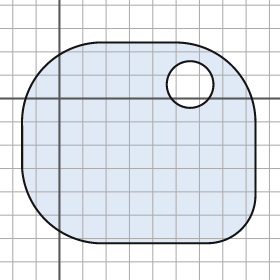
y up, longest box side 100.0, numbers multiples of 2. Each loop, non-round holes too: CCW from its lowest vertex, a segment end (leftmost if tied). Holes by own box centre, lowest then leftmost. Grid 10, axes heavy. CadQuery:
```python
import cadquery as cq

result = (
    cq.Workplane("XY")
    .moveTo(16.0, -62.0)
    .lineTo(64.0, -62.0)
    .threePointArc((78.0, -56.0), (84.0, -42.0))
    .lineTo(84.0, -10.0)
    .threePointArc((74.0, 14.0), (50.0, 24.0))
    .lineTo(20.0, 24.0)
    .threePointArc((-6.0, 14.0), (-16.0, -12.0))
    .lineTo(-16.0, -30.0)
    .threePointArc((-6.0, -52.0), (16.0, -62.0))
    .close()
    .moveTo(56.0, 6.0)
    .circle(10.0)
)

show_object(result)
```